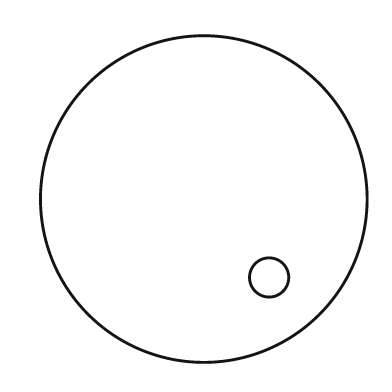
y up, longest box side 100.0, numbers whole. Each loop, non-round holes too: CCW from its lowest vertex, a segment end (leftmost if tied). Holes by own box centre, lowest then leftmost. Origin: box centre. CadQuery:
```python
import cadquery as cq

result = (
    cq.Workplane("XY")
    .moveTo(0.0, 0.0)
    .circle(50.0)
    .moveTo(20.0, -24.0)
    .circle(6.0)
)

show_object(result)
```